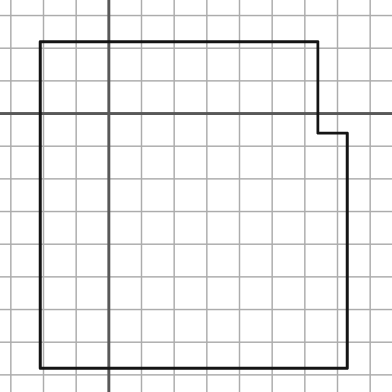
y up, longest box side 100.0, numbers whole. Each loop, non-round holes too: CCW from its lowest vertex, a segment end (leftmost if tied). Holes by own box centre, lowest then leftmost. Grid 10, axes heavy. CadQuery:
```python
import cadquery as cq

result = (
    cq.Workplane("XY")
    .moveTo(-21.0, -78.0)
    .lineTo(73.0, -78.0)
    .lineTo(73.0, -6.0)
    .lineTo(64.0, -6.0)
    .lineTo(64.0, 22.0)
    .lineTo(-21.0, 22.0)
    .close()
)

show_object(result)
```